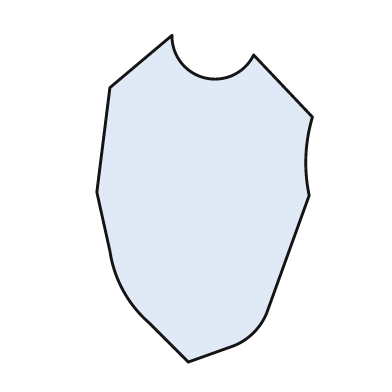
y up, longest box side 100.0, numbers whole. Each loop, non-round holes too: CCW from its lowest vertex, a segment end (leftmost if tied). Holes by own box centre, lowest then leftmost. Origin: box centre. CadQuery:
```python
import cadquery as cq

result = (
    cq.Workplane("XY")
    .moveTo(-5.0, -50.0)
    .lineTo(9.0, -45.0)
    .threePointArc((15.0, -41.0), (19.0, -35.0))
    .lineTo(32.0, 1.0)
    .threePointArc((31.0, 13.0), (33.0, 25.0))
    .lineTo(15.0, 44.0)
    .threePointArc((0.0, 37.0), (-10.0, 50.0))
    .lineTo(-29.0, 34.0)
    .lineTo(-33.0, 2.0)
    .lineTo(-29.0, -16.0)
    .threePointArc((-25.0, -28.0), (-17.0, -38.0))
    .close()
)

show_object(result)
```